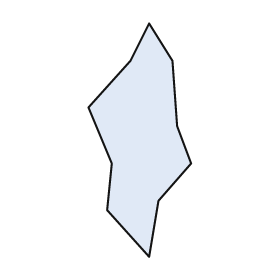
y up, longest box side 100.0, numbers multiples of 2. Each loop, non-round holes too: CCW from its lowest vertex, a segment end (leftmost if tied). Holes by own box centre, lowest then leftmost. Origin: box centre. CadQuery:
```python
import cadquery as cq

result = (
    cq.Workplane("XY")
    .moveTo(4.0, -50.0)
    .lineTo(8.0, -26.0)
    .lineTo(22.0, -10.0)
    .lineTo(16.0, 6.0)
    .lineTo(14.0, 34.0)
    .lineTo(4.0, 50.0)
    .lineTo(-4.0, 34.0)
    .lineTo(-22.0, 14.0)
    .lineTo(-12.0, -10.0)
    .lineTo(-14.0, -30.0)
    .close()
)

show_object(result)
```